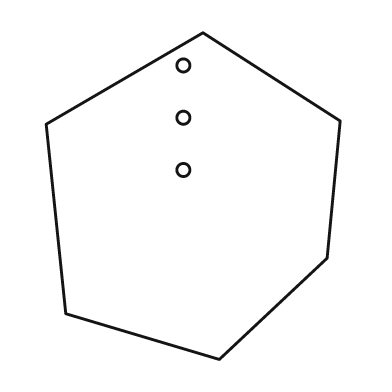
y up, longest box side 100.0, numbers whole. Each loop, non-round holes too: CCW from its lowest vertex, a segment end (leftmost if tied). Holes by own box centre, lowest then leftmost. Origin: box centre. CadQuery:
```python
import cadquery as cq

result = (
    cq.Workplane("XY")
    .moveTo(8.0, -50.0)
    .lineTo(41.0, -19.0)
    .lineTo(45.0, 23.0)
    .lineTo(3.0, 50.0)
    .lineTo(-45.0, 22.0)
    .lineTo(-39.0, -36.0)
    .close()
    .moveTo(-3.0, 8.0)
    .circle(2.0)
    .moveTo(-3.0, 24.0)
    .circle(2.0)
    .moveTo(-3.0, 40.0)
    .circle(2.0)
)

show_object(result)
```